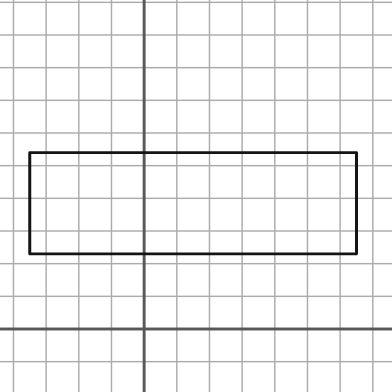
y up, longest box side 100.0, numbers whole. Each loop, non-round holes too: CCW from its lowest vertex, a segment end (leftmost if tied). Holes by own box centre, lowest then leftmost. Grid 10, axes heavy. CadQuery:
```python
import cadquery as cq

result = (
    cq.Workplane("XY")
    .moveTo(-35.0, 23.0)
    .lineTo(65.0, 23.0)
    .lineTo(65.0, 54.0)
    .lineTo(-35.0, 54.0)
    .close()
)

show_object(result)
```